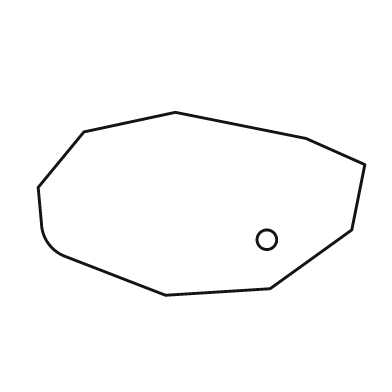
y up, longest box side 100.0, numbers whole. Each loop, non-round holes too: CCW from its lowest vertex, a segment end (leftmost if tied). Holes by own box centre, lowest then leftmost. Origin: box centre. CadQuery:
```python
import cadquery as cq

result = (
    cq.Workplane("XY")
    .moveTo(-11.0, -28.0)
    .lineTo(21.0, -26.0)
    .lineTo(46.0, -8.0)
    .lineTo(50.0, 12.0)
    .lineTo(32.0, 20.0)
    .lineTo(-8.0, 28.0)
    .lineTo(-36.0, 22.0)
    .lineTo(-50.0, 5.0)
    .lineTo(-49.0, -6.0)
    .threePointArc((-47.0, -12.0), (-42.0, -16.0))
    .close()
    .moveTo(20.0, -11.0)
    .circle(3.0)
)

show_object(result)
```